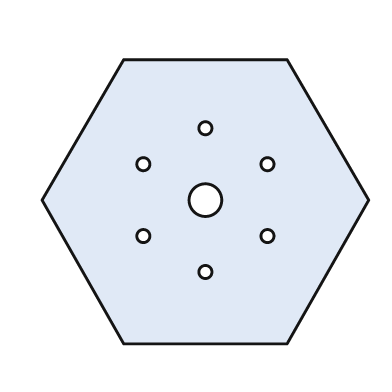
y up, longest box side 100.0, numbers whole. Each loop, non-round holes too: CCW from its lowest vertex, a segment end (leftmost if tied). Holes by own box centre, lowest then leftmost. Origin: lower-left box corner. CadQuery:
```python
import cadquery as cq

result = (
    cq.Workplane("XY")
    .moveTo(25.0, 0.0)
    .lineTo(75.0, 0.0)
    .lineTo(100.0, 44.0)
    .lineTo(75.0, 87.0)
    .lineTo(25.0, 87.0)
    .lineTo(0.0, 44.0)
    .close()
    .moveTo(50.0, 22.0)
    .circle(2.0)
    .moveTo(31.0, 33.0)
    .circle(2.0)
    .moveTo(69.0, 33.0)
    .circle(2.0)
    .moveTo(50.0, 44.0)
    .circle(5.0)
    .moveTo(31.0, 55.0)
    .circle(2.0)
    .moveTo(69.0, 55.0)
    .circle(2.0)
    .moveTo(50.0, 66.0)
    .circle(2.0)
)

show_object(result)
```